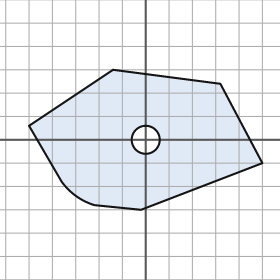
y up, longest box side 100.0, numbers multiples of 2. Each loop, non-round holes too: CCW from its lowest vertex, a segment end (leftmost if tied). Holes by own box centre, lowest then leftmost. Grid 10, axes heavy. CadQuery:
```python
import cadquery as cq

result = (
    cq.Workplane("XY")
    .moveTo(-2.0, -30.0)
    .lineTo(50.0, -10.0)
    .lineTo(32.0, 24.0)
    .lineTo(-14.0, 30.0)
    .lineTo(-50.0, 6.0)
    .lineTo(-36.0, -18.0)
    .threePointArc((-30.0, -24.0), (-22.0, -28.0))
    .close()
    .moveTo(0.0, 0.0)
    .circle(6.0)
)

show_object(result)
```